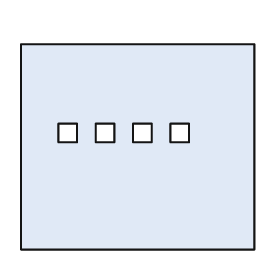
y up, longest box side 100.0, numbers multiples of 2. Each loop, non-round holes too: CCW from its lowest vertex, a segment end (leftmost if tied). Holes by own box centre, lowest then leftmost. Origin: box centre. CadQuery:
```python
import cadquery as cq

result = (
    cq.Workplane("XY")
    .moveTo(-50.0, -44.0)
    .lineTo(50.0, -44.0)
    .lineTo(50.0, 44.0)
    .lineTo(-50.0, 44.0)
    .close()
    .moveTo(-34.0, 2.0)
    .lineTo(-26.0, 2.0)
    .lineTo(-26.0, 10.0)
    .lineTo(-34.0, 10.0)
    .close()
    .moveTo(-18.0, 2.0)
    .lineTo(-10.0, 2.0)
    .lineTo(-10.0, 10.0)
    .lineTo(-18.0, 10.0)
    .close()
    .moveTo(-2.0, 2.0)
    .lineTo(6.0, 2.0)
    .lineTo(6.0, 10.0)
    .lineTo(-2.0, 10.0)
    .close()
    .moveTo(14.0, 2.0)
    .lineTo(22.0, 2.0)
    .lineTo(22.0, 10.0)
    .lineTo(14.0, 10.0)
    .close()
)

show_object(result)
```